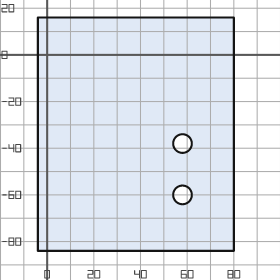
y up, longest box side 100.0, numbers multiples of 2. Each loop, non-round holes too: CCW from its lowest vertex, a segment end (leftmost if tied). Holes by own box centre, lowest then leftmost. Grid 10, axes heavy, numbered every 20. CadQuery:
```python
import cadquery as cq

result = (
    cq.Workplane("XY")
    .moveTo(-4.0, -84.0)
    .lineTo(80.0, -84.0)
    .lineTo(80.0, 16.0)
    .lineTo(-4.0, 16.0)
    .close()
    .moveTo(58.0, -60.0)
    .circle(4.0)
    .moveTo(58.0, -38.0)
    .circle(4.0)
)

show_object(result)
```